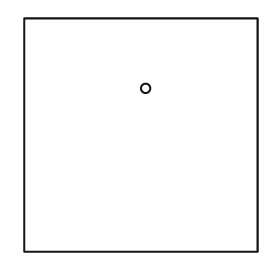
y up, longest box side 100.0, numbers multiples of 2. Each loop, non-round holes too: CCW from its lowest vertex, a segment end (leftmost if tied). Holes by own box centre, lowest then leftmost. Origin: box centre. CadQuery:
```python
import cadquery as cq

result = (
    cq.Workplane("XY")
    .moveTo(-50.0, -50.0)
    .lineTo(50.0, -50.0)
    .lineTo(50.0, 50.0)
    .lineTo(-50.0, 50.0)
    .close()
    .moveTo(2.0, 20.0)
    .circle(2.0)
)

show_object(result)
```